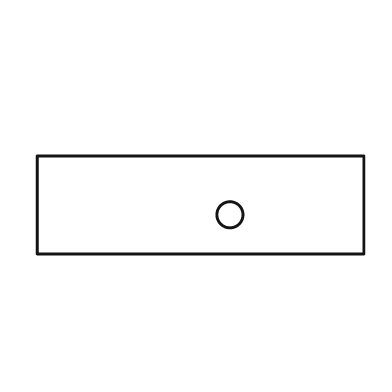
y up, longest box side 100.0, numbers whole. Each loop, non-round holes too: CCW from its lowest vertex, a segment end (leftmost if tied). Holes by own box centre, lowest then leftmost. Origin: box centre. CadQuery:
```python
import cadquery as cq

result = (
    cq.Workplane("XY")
    .moveTo(-50.0, -15.0)
    .lineTo(50.0, -15.0)
    .lineTo(50.0, 15.0)
    .lineTo(-50.0, 15.0)
    .close()
    .moveTo(9.0, -3.0)
    .circle(4.0)
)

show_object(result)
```